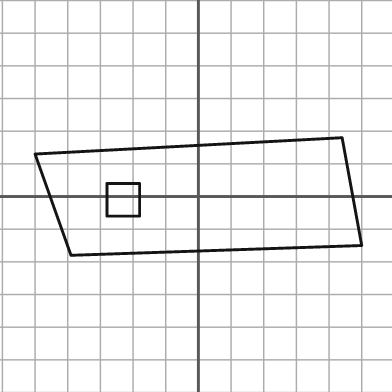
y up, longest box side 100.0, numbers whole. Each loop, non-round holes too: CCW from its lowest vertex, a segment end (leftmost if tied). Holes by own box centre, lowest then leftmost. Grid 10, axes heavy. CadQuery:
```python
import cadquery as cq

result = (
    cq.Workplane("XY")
    .moveTo(-39.0, -18.0)
    .lineTo(50.0, -15.0)
    .lineTo(44.0, 18.0)
    .lineTo(-50.0, 13.0)
    .close()
    .moveTo(-28.0, -6.0)
    .lineTo(-18.0, -6.0)
    .lineTo(-18.0, 4.0)
    .lineTo(-28.0, 4.0)
    .close()
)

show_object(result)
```